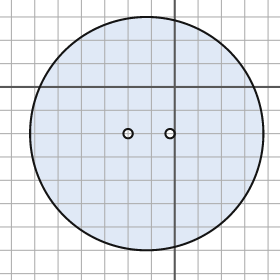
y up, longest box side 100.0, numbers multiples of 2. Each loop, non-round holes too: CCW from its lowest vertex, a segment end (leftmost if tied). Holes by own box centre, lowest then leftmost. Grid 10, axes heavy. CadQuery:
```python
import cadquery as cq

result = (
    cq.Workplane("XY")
    .moveTo(-12.0, -20.0)
    .circle(50.0)
    .moveTo(-20.0, -20.0)
    .circle(2.0)
    .moveTo(-2.0, -20.0)
    .circle(2.0)
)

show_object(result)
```